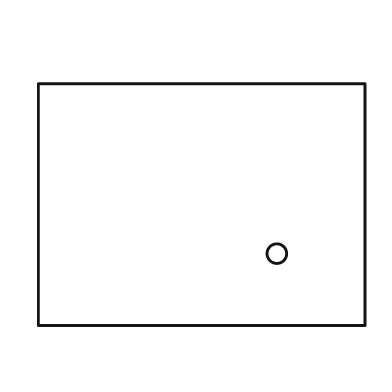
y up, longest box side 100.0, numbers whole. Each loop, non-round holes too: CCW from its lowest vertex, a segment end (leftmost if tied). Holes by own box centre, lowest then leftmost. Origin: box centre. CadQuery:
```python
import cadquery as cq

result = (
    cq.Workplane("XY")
    .moveTo(-50.0, -37.0)
    .lineTo(50.0, -37.0)
    .lineTo(50.0, 37.0)
    .lineTo(-50.0, 37.0)
    .close()
    .moveTo(23.0, -15.0)
    .circle(3.0)
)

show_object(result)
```